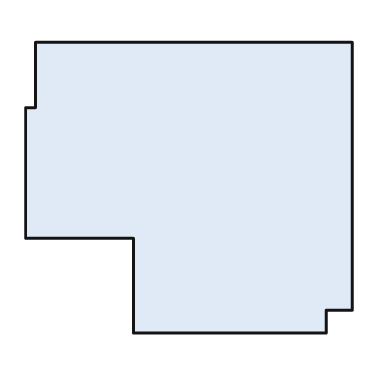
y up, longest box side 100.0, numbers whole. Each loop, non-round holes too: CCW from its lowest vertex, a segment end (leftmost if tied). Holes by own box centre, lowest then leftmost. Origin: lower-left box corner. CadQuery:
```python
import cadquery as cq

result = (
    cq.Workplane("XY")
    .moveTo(33.0, 0.0)
    .lineTo(92.0, 0.0)
    .lineTo(92.0, 7.0)
    .lineTo(100.0, 7.0)
    .lineTo(100.0, 89.0)
    .lineTo(3.0, 89.0)
    .lineTo(3.0, 69.0)
    .lineTo(0.0, 69.0)
    .lineTo(0.0, 29.0)
    .lineTo(33.0, 29.0)
    .close()
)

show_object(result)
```